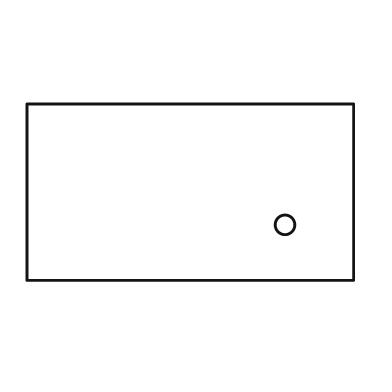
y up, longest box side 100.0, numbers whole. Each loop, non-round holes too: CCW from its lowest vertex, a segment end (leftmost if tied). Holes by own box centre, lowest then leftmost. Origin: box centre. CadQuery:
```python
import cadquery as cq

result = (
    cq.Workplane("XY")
    .moveTo(-50.0, -27.0)
    .lineTo(50.0, -27.0)
    .lineTo(50.0, 27.0)
    .lineTo(-50.0, 27.0)
    .close()
    .moveTo(29.0, -10.0)
    .circle(3.0)
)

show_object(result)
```